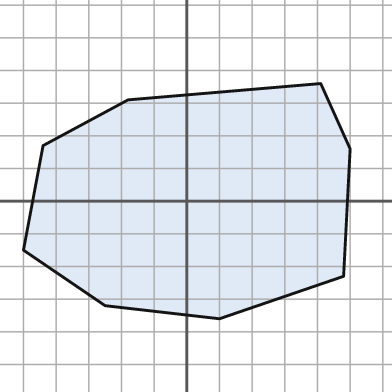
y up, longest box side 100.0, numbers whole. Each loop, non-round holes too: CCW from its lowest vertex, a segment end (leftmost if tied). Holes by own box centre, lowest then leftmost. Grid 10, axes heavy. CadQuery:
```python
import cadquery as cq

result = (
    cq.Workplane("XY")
    .moveTo(10.0, -36.0)
    .lineTo(48.0, -23.0)
    .lineTo(50.0, 16.0)
    .lineTo(41.0, 36.0)
    .lineTo(-18.0, 31.0)
    .lineTo(-44.0, 17.0)
    .lineTo(-50.0, -15.0)
    .lineTo(-25.0, -32.0)
    .close()
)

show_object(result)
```